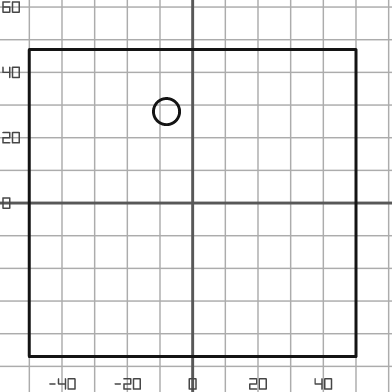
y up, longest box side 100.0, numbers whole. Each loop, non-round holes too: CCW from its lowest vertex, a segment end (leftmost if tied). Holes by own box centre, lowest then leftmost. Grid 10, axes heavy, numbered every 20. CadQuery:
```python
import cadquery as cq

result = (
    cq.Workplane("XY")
    .moveTo(-50.0, -47.0)
    .lineTo(50.0, -47.0)
    .lineTo(50.0, 47.0)
    .lineTo(-50.0, 47.0)
    .close()
    .moveTo(-8.0, 28.0)
    .circle(4.0)
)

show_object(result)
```